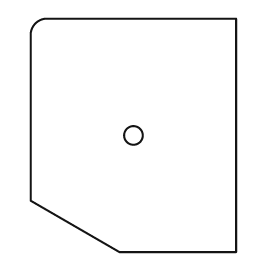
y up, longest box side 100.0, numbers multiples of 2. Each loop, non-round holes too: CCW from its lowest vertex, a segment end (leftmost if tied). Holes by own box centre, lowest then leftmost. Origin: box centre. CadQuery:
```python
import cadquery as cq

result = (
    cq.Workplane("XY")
    .moveTo(-6.0, -50.0)
    .lineTo(44.0, -50.0)
    .lineTo(44.0, 50.0)
    .lineTo(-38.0, 50.0)
    .threePointArc((-42.0, 48.0), (-44.0, 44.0))
    .lineTo(-44.0, -28.0)
    .close()
    .moveTo(0.0, 0.0)
    .circle(4.0)
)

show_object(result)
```